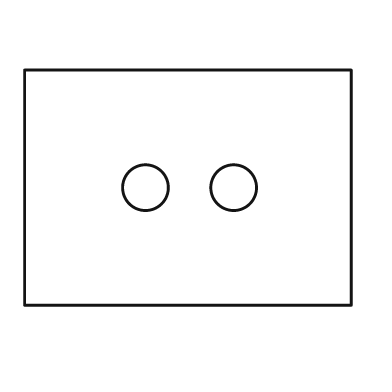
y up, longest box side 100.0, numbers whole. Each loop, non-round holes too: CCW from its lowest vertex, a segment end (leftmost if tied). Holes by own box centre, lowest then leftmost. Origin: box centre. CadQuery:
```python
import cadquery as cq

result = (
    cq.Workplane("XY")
    .moveTo(-50.0, -36.0)
    .lineTo(50.0, -36.0)
    .lineTo(50.0, 36.0)
    .lineTo(-50.0, 36.0)
    .close()
    .moveTo(-13.0, 0.0)
    .circle(7.0)
    .moveTo(14.0, 0.0)
    .circle(7.0)
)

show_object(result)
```